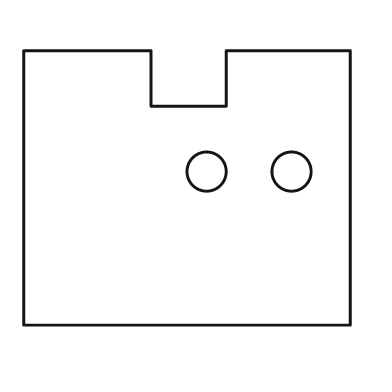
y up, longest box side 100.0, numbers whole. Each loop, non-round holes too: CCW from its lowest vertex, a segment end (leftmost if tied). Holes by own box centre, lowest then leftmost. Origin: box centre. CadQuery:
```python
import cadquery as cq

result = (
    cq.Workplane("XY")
    .moveTo(-50.0, -42.0)
    .lineTo(50.0, -42.0)
    .lineTo(50.0, 42.0)
    .lineTo(12.0, 42.0)
    .lineTo(12.0, 25.0)
    .lineTo(-11.0, 25.0)
    .lineTo(-11.0, 42.0)
    .lineTo(-50.0, 42.0)
    .close()
    .moveTo(6.0, 5.0)
    .circle(6.0)
    .moveTo(32.0, 5.0)
    .circle(6.0)
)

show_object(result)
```